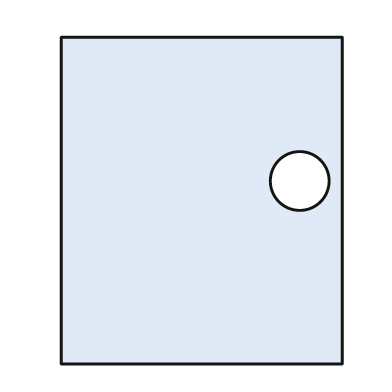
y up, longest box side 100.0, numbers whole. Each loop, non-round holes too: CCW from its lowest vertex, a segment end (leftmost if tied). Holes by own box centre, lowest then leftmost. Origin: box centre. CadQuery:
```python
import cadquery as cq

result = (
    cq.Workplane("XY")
    .moveTo(-43.0, -50.0)
    .lineTo(43.0, -50.0)
    .lineTo(43.0, 50.0)
    .lineTo(-43.0, 50.0)
    .close()
    .moveTo(30.0, 6.0)
    .circle(9.0)
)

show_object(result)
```